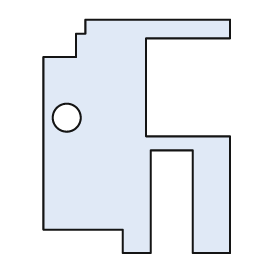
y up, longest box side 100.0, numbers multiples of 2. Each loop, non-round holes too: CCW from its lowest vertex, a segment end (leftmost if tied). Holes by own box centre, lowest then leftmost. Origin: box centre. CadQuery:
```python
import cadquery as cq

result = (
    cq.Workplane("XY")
    .moveTo(-6.0, -50.0)
    .lineTo(6.0, -50.0)
    .lineTo(6.0, -6.0)
    .lineTo(24.0, -6.0)
    .lineTo(24.0, -50.0)
    .lineTo(40.0, -50.0)
    .lineTo(40.0, 0.0)
    .lineTo(4.0, 0.0)
    .lineTo(4.0, 42.0)
    .lineTo(40.0, 42.0)
    .lineTo(40.0, 50.0)
    .lineTo(-22.0, 50.0)
    .lineTo(-22.0, 44.0)
    .lineTo(-26.0, 44.0)
    .lineTo(-26.0, 34.0)
    .lineTo(-40.0, 34.0)
    .lineTo(-40.0, -40.0)
    .lineTo(-6.0, -40.0)
    .close()
    .moveTo(-30.0, 8.0)
    .circle(6.0)
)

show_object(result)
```